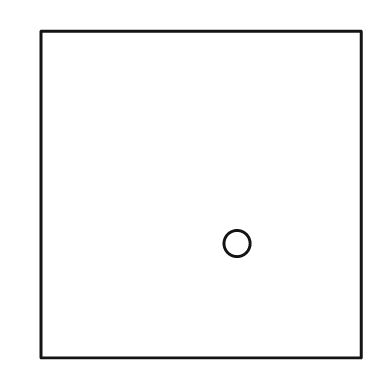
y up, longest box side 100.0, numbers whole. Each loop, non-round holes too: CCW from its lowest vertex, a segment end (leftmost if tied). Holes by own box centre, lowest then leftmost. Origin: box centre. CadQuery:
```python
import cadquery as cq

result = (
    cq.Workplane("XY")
    .moveTo(-49.0, -50.0)
    .lineTo(49.0, -50.0)
    .lineTo(49.0, 50.0)
    .lineTo(-49.0, 50.0)
    .close()
    .moveTo(11.0, -15.0)
    .circle(4.0)
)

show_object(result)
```